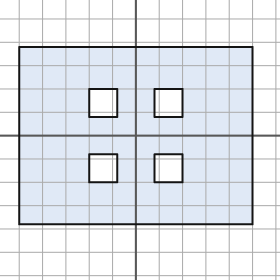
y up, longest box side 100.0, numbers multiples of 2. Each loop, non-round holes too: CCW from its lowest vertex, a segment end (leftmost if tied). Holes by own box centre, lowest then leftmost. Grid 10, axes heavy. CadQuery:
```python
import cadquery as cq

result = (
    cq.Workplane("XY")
    .moveTo(-50.0, -38.0)
    .lineTo(50.0, -38.0)
    .lineTo(50.0, 38.0)
    .lineTo(-50.0, 38.0)
    .close()
    .moveTo(-20.0, -20.0)
    .lineTo(-8.0, -20.0)
    .lineTo(-8.0, -8.0)
    .lineTo(-20.0, -8.0)
    .close()
    .moveTo(8.0, -20.0)
    .lineTo(20.0, -20.0)
    .lineTo(20.0, -8.0)
    .lineTo(8.0, -8.0)
    .close()
    .moveTo(-20.0, 8.0)
    .lineTo(-8.0, 8.0)
    .lineTo(-8.0, 20.0)
    .lineTo(-20.0, 20.0)
    .close()
    .moveTo(8.0, 8.0)
    .lineTo(20.0, 8.0)
    .lineTo(20.0, 20.0)
    .lineTo(8.0, 20.0)
    .close()
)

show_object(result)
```